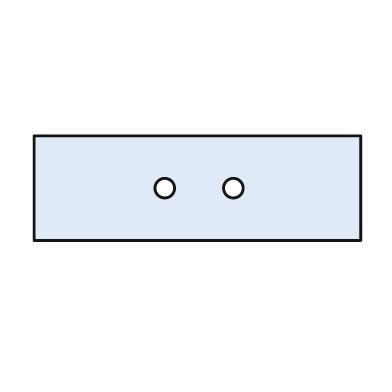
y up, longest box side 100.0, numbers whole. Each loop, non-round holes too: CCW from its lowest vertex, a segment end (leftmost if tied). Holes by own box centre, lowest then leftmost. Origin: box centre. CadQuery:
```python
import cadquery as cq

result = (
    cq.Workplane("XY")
    .moveTo(-50.0, -16.0)
    .lineTo(50.0, -16.0)
    .lineTo(50.0, 16.0)
    .lineTo(-50.0, 16.0)
    .close()
    .moveTo(-10.0, 0.0)
    .circle(3.0)
    .moveTo(11.0, 0.0)
    .circle(3.0)
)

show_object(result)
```